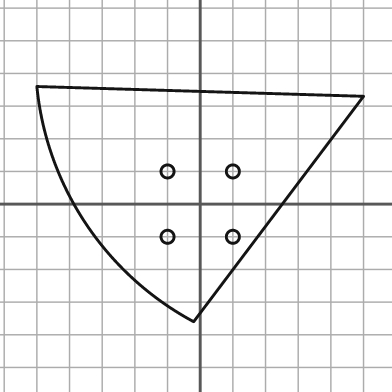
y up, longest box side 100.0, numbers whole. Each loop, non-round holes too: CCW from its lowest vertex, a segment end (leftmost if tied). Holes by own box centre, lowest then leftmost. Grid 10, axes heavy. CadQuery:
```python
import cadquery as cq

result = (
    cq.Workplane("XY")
    .moveTo(-2.0, -36.0)
    .lineTo(50.0, 33.0)
    .lineTo(-50.0, 36.0)
    .threePointArc((-35.0, -6.0), (-2.0, -36.0))
    .close()
    .moveTo(-10.0, -10.0)
    .circle(2.0)
    .moveTo(10.0, -10.0)
    .circle(2.0)
    .moveTo(-10.0, 10.0)
    .circle(2.0)
    .moveTo(10.0, 10.0)
    .circle(2.0)
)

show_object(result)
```